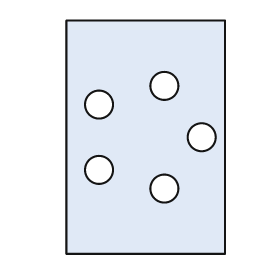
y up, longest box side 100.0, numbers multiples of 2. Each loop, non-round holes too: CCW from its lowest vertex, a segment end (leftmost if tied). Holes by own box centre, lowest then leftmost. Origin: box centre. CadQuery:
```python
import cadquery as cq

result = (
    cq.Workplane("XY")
    .moveTo(-34.0, -50.0)
    .lineTo(34.0, -50.0)
    .lineTo(34.0, 50.0)
    .lineTo(-34.0, 50.0)
    .close()
    .moveTo(8.0, -22.0)
    .circle(6.0)
    .moveTo(-20.0, -14.0)
    .circle(6.0)
    .moveTo(24.0, 0.0)
    .circle(6.0)
    .moveTo(-20.0, 14.0)
    .circle(6.0)
    .moveTo(8.0, 22.0)
    .circle(6.0)
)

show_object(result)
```